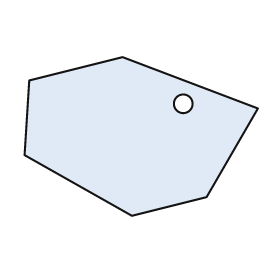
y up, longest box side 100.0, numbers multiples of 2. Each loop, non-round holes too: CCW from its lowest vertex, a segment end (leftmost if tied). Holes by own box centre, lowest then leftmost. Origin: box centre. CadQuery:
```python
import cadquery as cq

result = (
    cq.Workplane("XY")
    .moveTo(-4.0, -34.0)
    .lineTo(28.0, -26.0)
    .lineTo(50.0, 12.0)
    .lineTo(-8.0, 34.0)
    .lineTo(-48.0, 24.0)
    .lineTo(-50.0, -8.0)
    .close()
    .moveTo(18.0, 14.0)
    .circle(4.0)
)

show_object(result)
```